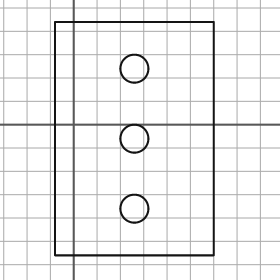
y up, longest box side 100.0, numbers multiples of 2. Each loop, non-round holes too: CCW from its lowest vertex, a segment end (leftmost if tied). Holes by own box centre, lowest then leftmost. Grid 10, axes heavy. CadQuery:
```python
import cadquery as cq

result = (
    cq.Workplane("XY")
    .moveTo(-8.0, -56.0)
    .lineTo(60.0, -56.0)
    .lineTo(60.0, 44.0)
    .lineTo(-8.0, 44.0)
    .close()
    .moveTo(26.0, -36.0)
    .circle(6.0)
    .moveTo(26.0, -6.0)
    .circle(6.0)
    .moveTo(26.0, 24.0)
    .circle(6.0)
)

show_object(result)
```